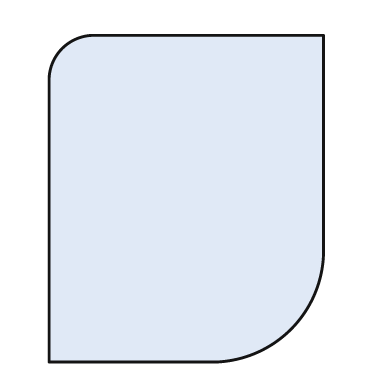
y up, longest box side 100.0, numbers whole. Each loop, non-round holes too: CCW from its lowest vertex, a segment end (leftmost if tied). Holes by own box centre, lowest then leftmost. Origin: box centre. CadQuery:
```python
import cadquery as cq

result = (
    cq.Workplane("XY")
    .moveTo(-42.0, -50.0)
    .lineTo(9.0, -50.0)
    .threePointArc((32.0, -40.0), (42.0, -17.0))
    .lineTo(42.0, 50.0)
    .lineTo(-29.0, 50.0)
    .threePointArc((-38.0, 46.0), (-42.0, 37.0))
    .close()
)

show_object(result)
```